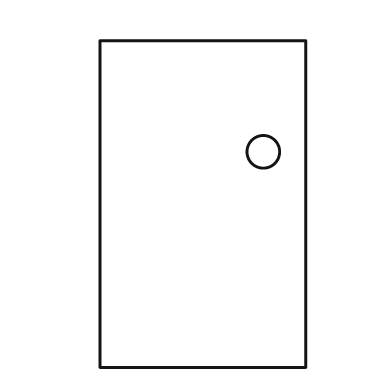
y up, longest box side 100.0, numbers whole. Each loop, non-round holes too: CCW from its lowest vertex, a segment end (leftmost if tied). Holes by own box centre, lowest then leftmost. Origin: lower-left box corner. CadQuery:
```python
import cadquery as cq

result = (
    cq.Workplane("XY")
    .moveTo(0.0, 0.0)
    .lineTo(63.0, 0.0)
    .lineTo(63.0, 100.0)
    .lineTo(0.0, 100.0)
    .close()
    .moveTo(50.0, 66.0)
    .circle(5.0)
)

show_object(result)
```